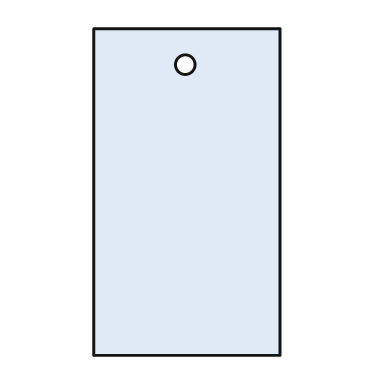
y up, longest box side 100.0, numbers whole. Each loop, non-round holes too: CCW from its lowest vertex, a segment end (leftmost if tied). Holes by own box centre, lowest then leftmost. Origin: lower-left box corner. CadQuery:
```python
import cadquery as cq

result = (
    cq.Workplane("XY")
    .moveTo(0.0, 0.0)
    .lineTo(57.0, 0.0)
    .lineTo(57.0, 100.0)
    .lineTo(0.0, 100.0)
    .close()
    .moveTo(28.0, 89.0)
    .circle(3.0)
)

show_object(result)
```